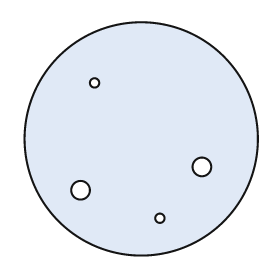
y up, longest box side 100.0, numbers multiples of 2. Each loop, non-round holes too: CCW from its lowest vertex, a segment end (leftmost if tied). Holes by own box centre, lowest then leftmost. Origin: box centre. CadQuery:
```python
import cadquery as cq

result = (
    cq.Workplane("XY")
    .moveTo(0.0, 0.0)
    .circle(50.0)
    .moveTo(8.0, -34.0)
    .circle(2.0)
    .moveTo(-26.0, -22.0)
    .circle(4.0)
    .moveTo(26.0, -12.0)
    .circle(4.0)
    .moveTo(-20.0, 24.0)
    .circle(2.0)
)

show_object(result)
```